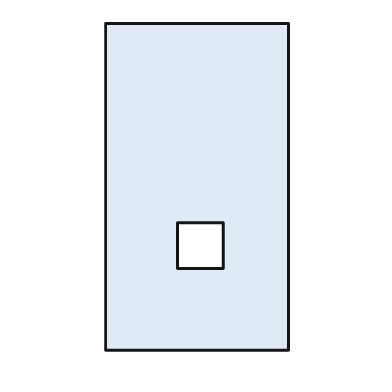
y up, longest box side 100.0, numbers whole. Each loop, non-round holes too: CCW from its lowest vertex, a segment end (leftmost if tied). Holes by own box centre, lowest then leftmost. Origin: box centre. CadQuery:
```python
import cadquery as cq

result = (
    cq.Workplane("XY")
    .moveTo(-28.0, -50.0)
    .lineTo(28.0, -50.0)
    .lineTo(28.0, 50.0)
    .lineTo(-28.0, 50.0)
    .close()
    .moveTo(-6.0, -25.0)
    .lineTo(8.0, -25.0)
    .lineTo(8.0, -11.0)
    .lineTo(-6.0, -11.0)
    .close()
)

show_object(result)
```